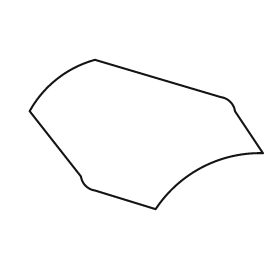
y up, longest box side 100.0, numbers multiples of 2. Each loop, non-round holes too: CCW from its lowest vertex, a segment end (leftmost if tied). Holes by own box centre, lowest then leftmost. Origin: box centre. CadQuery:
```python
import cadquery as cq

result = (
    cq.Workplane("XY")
    .moveTo(4.0, -32.0)
    .threePointArc((24.0, -14.0), (50.0, -8.0))
    .lineTo(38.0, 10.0)
    .threePointArc((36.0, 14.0), (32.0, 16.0))
    .lineTo(-22.0, 32.0)
    .threePointArc((-38.0, 24.0), (-50.0, 10.0))
    .lineTo(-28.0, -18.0)
    .threePointArc((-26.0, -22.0), (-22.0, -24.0))
    .close()
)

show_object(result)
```